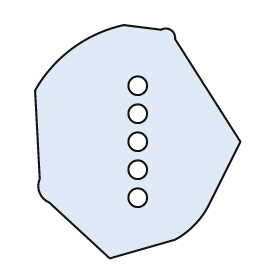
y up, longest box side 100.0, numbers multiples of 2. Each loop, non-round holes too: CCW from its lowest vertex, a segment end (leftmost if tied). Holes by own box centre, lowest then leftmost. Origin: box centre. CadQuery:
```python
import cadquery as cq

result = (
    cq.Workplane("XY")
    .moveTo(-12.0, -50.0)
    .lineTo(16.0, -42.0)
    .threePointArc((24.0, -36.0), (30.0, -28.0))
    .lineTo(44.0, 0.0)
    .lineTo(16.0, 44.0)
    .threePointArc((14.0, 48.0), (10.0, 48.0))
    .lineTo(-6.0, 50.0)
    .threePointArc((-28.0, 40.0), (-44.0, 22.0))
    .lineTo(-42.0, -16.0)
    .threePointArc((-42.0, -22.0), (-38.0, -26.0))
    .close()
    .moveTo(0.0, -24.0)
    .circle(4.0)
    .moveTo(0.0, -12.0)
    .circle(4.0)
    .moveTo(0.0, 0.0)
    .circle(4.0)
    .moveTo(0.0, 12.0)
    .circle(4.0)
    .moveTo(0.0, 24.0)
    .circle(4.0)
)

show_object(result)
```